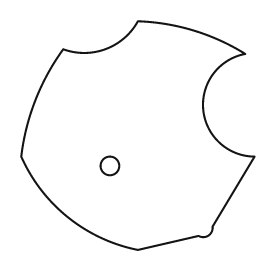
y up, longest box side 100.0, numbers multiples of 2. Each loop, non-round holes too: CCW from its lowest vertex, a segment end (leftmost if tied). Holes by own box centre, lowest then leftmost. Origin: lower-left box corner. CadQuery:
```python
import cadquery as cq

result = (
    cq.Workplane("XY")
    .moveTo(50.0, 0.0)
    .lineTo(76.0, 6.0)
    .threePointArc((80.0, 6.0), (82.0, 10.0))
    .lineTo(100.0, 40.0)
    .threePointArc((78.0, 60.0), (96.0, 84.0))
    .threePointArc((74.0, 94.0), (50.0, 98.0))
    .threePointArc((36.0, 86.0), (18.0, 86.0))
    .threePointArc((6.0, 64.0), (0.0, 40.0))
    .threePointArc((20.0, 14.0), (50.0, 0.0))
    .close()
    .moveTo(38.0, 36.0)
    .circle(4.0)
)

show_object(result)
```